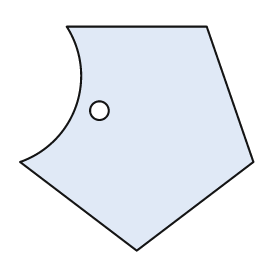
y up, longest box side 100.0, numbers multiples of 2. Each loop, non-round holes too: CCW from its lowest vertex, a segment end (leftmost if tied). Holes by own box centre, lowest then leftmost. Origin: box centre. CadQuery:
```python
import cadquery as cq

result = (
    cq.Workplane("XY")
    .moveTo(0.0, -48.0)
    .lineTo(50.0, -10.0)
    .lineTo(30.0, 48.0)
    .lineTo(-30.0, 48.0)
    .threePointArc((-26.0, 14.0), (-50.0, -10.0))
    .close()
    .moveTo(-16.0, 12.0)
    .circle(4.0)
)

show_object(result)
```